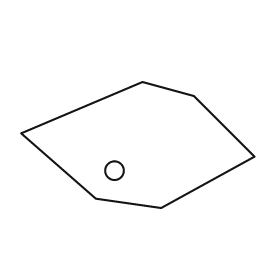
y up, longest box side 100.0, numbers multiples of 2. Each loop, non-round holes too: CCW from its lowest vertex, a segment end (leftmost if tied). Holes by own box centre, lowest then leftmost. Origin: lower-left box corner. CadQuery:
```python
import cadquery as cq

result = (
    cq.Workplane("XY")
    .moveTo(60.0, 0.0)
    .lineTo(100.0, 22.0)
    .lineTo(74.0, 48.0)
    .lineTo(52.0, 54.0)
    .lineTo(0.0, 32.0)
    .lineTo(32.0, 4.0)
    .close()
    .moveTo(40.0, 16.0)
    .circle(4.0)
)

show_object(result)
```